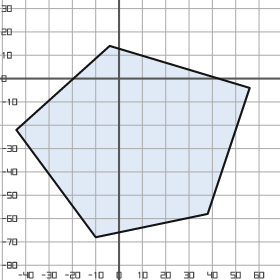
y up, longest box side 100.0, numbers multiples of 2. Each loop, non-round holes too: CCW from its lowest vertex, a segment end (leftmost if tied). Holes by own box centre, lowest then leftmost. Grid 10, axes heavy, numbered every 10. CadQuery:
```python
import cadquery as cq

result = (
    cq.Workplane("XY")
    .moveTo(-10.0, -68.0)
    .lineTo(38.0, -58.0)
    .lineTo(56.0, -4.0)
    .lineTo(-4.0, 14.0)
    .lineTo(-44.0, -22.0)
    .close()
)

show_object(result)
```